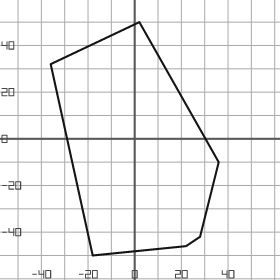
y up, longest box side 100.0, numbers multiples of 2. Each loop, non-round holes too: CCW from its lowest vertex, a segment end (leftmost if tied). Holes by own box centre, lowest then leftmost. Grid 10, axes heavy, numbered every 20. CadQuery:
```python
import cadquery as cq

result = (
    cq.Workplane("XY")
    .moveTo(-18.0, -50.0)
    .lineTo(22.0, -46.0)
    .lineTo(28.0, -42.0)
    .lineTo(36.0, -10.0)
    .lineTo(2.0, 50.0)
    .lineTo(-36.0, 32.0)
    .close()
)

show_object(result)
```